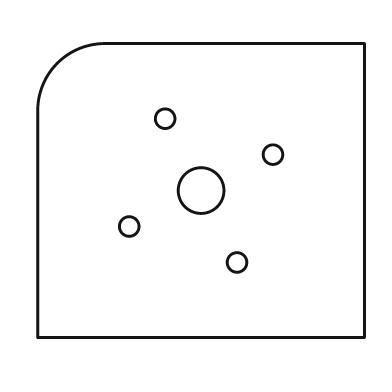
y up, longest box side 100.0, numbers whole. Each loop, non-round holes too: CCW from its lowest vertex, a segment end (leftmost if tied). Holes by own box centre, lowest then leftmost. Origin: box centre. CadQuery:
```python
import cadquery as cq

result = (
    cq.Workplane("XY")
    .moveTo(-50.0, -45.0)
    .lineTo(50.0, -45.0)
    .lineTo(50.0, 45.0)
    .lineTo(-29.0, 45.0)
    .threePointArc((-44.0, 39.0), (-50.0, 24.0))
    .close()
    .moveTo(11.0, -22.0)
    .circle(3.0)
    .moveTo(-22.0, -11.0)
    .circle(3.0)
    .moveTo(0.0, 0.0)
    .circle(7.0)
    .moveTo(22.0, 11.0)
    .circle(3.0)
    .moveTo(-11.0, 22.0)
    .circle(3.0)
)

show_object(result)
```